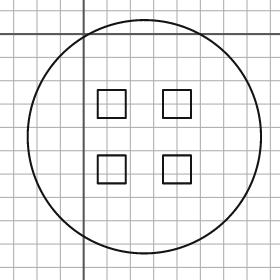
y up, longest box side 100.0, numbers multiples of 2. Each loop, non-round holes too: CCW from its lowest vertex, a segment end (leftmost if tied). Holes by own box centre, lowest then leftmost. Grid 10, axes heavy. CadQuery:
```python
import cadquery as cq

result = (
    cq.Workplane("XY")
    .moveTo(26.0, -44.0)
    .circle(50.0)
    .moveTo(6.0, -64.0)
    .lineTo(18.0, -64.0)
    .lineTo(18.0, -52.0)
    .lineTo(6.0, -52.0)
    .close()
    .moveTo(34.0, -64.0)
    .lineTo(46.0, -64.0)
    .lineTo(46.0, -52.0)
    .lineTo(34.0, -52.0)
    .close()
    .moveTo(6.0, -36.0)
    .lineTo(18.0, -36.0)
    .lineTo(18.0, -24.0)
    .lineTo(6.0, -24.0)
    .close()
    .moveTo(34.0, -36.0)
    .lineTo(46.0, -36.0)
    .lineTo(46.0, -24.0)
    .lineTo(34.0, -24.0)
    .close()
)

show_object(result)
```